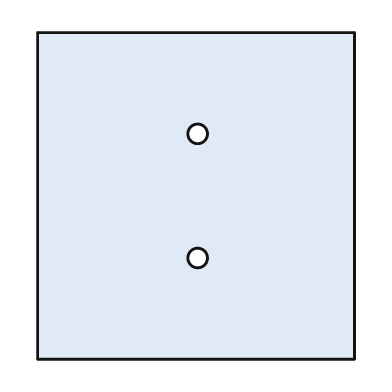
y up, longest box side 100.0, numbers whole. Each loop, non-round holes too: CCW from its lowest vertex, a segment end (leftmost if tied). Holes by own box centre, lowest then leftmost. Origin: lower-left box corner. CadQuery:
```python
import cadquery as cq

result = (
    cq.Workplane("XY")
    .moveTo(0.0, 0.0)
    .lineTo(97.0, 0.0)
    .lineTo(97.0, 100.0)
    .lineTo(0.0, 100.0)
    .close()
    .moveTo(49.0, 31.0)
    .circle(3.0)
    .moveTo(49.0, 69.0)
    .circle(3.0)
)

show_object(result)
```